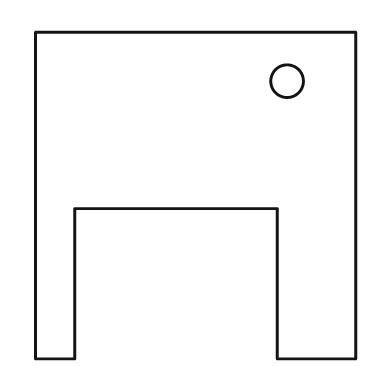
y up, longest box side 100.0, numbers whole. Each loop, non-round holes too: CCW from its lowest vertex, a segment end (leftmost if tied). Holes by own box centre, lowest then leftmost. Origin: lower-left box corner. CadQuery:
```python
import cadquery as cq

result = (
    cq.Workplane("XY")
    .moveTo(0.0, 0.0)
    .lineTo(12.0, 0.0)
    .lineTo(12.0, 46.0)
    .lineTo(74.0, 46.0)
    .lineTo(74.0, 0.0)
    .lineTo(98.0, 0.0)
    .lineTo(98.0, 100.0)
    .lineTo(0.0, 100.0)
    .close()
    .moveTo(77.0, 85.0)
    .circle(5.0)
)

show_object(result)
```